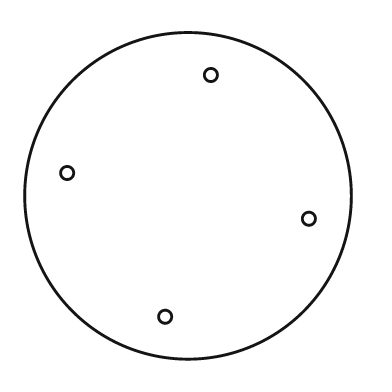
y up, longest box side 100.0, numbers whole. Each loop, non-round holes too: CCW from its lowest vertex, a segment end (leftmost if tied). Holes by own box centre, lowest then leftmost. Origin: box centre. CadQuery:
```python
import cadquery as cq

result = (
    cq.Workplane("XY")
    .moveTo(0.0, 0.0)
    .circle(50.0)
    .moveTo(-7.0, -37.0)
    .circle(2.0)
    .moveTo(37.0, -7.0)
    .circle(2.0)
    .moveTo(-37.0, 7.0)
    .circle(2.0)
    .moveTo(7.0, 37.0)
    .circle(2.0)
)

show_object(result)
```